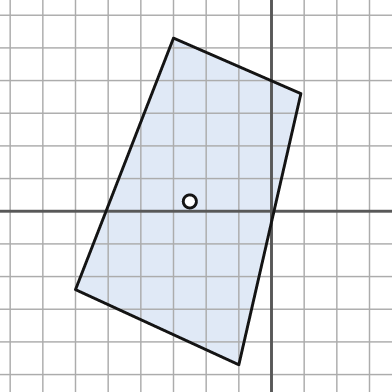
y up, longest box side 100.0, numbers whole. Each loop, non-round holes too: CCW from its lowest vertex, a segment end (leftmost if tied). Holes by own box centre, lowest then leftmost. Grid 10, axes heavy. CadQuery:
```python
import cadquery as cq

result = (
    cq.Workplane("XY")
    .moveTo(-10.0, -47.0)
    .lineTo(9.0, 36.0)
    .lineTo(-30.0, 53.0)
    .lineTo(-60.0, -24.0)
    .close()
    .moveTo(-25.0, 3.0)
    .circle(2.0)
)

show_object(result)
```